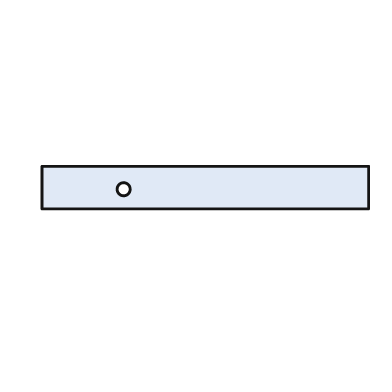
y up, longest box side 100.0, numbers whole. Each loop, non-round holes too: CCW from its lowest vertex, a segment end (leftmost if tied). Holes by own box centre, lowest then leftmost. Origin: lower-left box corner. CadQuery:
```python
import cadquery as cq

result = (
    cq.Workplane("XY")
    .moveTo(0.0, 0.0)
    .lineTo(100.0, 0.0)
    .lineTo(100.0, 13.0)
    .lineTo(0.0, 13.0)
    .close()
    .moveTo(25.0, 6.0)
    .circle(2.0)
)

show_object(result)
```